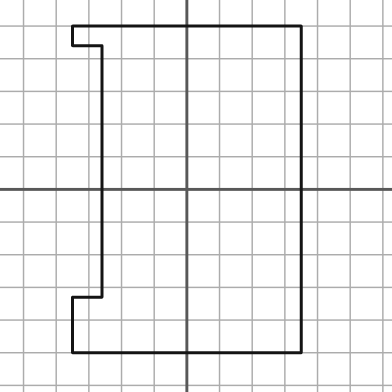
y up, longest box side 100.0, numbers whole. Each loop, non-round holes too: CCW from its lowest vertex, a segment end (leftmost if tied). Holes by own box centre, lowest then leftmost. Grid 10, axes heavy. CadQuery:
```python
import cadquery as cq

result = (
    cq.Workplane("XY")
    .moveTo(-35.0, -50.0)
    .lineTo(35.0, -50.0)
    .lineTo(35.0, 50.0)
    .lineTo(-35.0, 50.0)
    .lineTo(-35.0, 44.0)
    .lineTo(-26.0, 44.0)
    .lineTo(-26.0, -33.0)
    .lineTo(-35.0, -33.0)
    .close()
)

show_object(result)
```